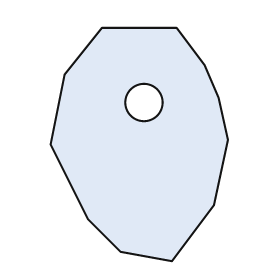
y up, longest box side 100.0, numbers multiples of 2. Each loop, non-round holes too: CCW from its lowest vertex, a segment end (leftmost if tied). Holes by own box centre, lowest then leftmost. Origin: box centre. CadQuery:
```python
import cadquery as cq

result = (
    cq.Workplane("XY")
    .moveTo(14.0, -50.0)
    .lineTo(32.0, -26.0)
    .lineTo(38.0, 2.0)
    .lineTo(34.0, 20.0)
    .lineTo(28.0, 34.0)
    .lineTo(16.0, 50.0)
    .lineTo(-16.0, 50.0)
    .lineTo(-32.0, 30.0)
    .lineTo(-38.0, 0.0)
    .lineTo(-22.0, -32.0)
    .lineTo(-8.0, -46.0)
    .close()
    .moveTo(2.0, 18.0)
    .circle(8.0)
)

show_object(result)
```